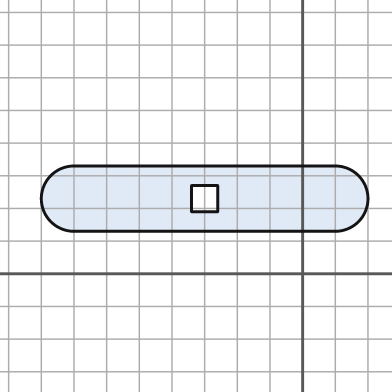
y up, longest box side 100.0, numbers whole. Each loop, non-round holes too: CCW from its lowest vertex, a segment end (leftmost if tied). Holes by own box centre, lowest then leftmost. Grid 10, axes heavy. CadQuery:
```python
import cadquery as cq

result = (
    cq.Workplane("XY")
    .moveTo(-70.0, 13.0)
    .lineTo(10.0, 13.0)
    .threePointArc((20.0, 23.0), (10.0, 33.0))
    .lineTo(-70.0, 33.0)
    .threePointArc((-80.0, 23.0), (-70.0, 13.0))
    .close()
    .moveTo(-34.0, 19.0)
    .lineTo(-26.0, 19.0)
    .lineTo(-26.0, 27.0)
    .lineTo(-34.0, 27.0)
    .close()
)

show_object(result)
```